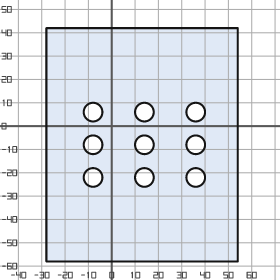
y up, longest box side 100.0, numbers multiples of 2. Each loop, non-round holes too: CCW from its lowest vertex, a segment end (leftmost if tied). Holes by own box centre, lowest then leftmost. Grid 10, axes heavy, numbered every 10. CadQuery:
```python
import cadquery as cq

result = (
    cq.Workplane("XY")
    .moveTo(-28.0, -58.0)
    .lineTo(54.0, -58.0)
    .lineTo(54.0, 42.0)
    .lineTo(-28.0, 42.0)
    .close()
    .moveTo(-8.0, -22.0)
    .circle(4.0)
    .moveTo(14.0, -22.0)
    .circle(4.0)
    .moveTo(36.0, -22.0)
    .circle(4.0)
    .moveTo(-8.0, -8.0)
    .circle(4.0)
    .moveTo(14.0, -8.0)
    .circle(4.0)
    .moveTo(36.0, -8.0)
    .circle(4.0)
    .moveTo(-8.0, 6.0)
    .circle(4.0)
    .moveTo(14.0, 6.0)
    .circle(4.0)
    .moveTo(36.0, 6.0)
    .circle(4.0)
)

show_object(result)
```